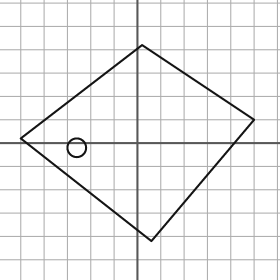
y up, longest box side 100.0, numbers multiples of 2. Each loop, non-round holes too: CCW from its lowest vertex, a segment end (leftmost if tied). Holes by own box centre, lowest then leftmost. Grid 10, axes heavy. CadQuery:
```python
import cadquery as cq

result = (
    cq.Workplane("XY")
    .moveTo(6.0, -42.0)
    .lineTo(50.0, 10.0)
    .lineTo(2.0, 42.0)
    .lineTo(-50.0, 2.0)
    .close()
    .moveTo(-26.0, -2.0)
    .circle(4.0)
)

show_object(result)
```